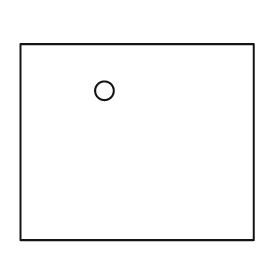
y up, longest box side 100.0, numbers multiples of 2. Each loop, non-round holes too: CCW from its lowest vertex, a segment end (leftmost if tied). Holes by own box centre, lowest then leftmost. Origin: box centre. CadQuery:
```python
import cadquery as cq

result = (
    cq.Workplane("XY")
    .moveTo(-50.0, -42.0)
    .lineTo(50.0, -42.0)
    .lineTo(50.0, 42.0)
    .lineTo(-50.0, 42.0)
    .close()
    .moveTo(-14.0, 22.0)
    .circle(4.0)
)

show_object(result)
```